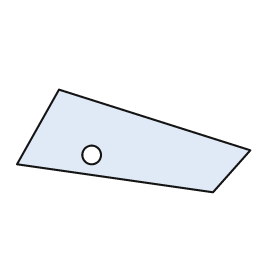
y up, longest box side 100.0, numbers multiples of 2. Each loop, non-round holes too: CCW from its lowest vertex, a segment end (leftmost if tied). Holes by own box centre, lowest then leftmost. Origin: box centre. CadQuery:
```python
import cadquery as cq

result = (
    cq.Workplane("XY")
    .moveTo(34.0, -22.0)
    .lineTo(50.0, -4.0)
    .lineTo(-32.0, 22.0)
    .lineTo(-50.0, -10.0)
    .close()
    .moveTo(-18.0, -6.0)
    .circle(4.0)
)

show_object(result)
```